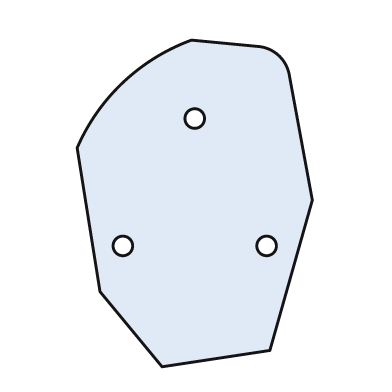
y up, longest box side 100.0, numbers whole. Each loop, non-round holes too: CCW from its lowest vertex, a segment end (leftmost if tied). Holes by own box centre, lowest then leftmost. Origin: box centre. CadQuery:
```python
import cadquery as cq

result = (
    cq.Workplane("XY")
    .moveTo(-10.0, -50.0)
    .lineTo(23.0, -45.0)
    .lineTo(36.0, 1.0)
    .lineTo(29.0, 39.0)
    .threePointArc((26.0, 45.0), (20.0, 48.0))
    .lineTo(-1.0, 50.0)
    .threePointArc((-22.0, 37.0), (-36.0, 17.0))
    .lineTo(-29.0, -27.0)
    .close()
    .moveTo(-22.0, -13.0)
    .circle(3.0)
    .moveTo(22.0, -13.0)
    .circle(3.0)
    .moveTo(0.0, 26.0)
    .circle(3.0)
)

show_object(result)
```